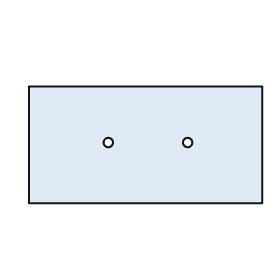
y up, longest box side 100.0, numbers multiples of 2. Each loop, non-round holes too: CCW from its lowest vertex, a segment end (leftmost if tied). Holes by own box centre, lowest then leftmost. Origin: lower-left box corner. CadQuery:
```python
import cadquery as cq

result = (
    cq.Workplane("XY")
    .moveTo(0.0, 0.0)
    .lineTo(100.0, 0.0)
    .lineTo(100.0, 50.0)
    .lineTo(0.0, 50.0)
    .close()
    .moveTo(34.0, 26.0)
    .circle(2.0)
    .moveTo(68.0, 26.0)
    .circle(2.0)
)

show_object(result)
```